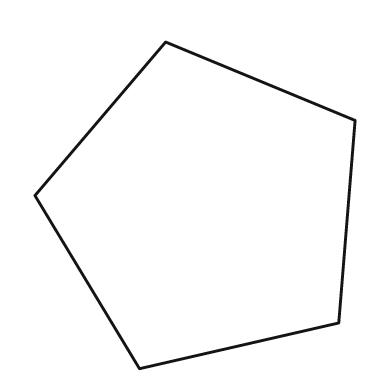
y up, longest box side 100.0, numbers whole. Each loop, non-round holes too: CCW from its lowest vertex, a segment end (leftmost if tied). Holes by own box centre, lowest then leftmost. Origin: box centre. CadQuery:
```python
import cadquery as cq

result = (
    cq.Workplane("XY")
    .moveTo(-17.0, -50.0)
    .lineTo(44.0, -36.0)
    .lineTo(49.0, 26.0)
    .lineTo(-9.0, 50.0)
    .lineTo(-49.0, 3.0)
    .close()
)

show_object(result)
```